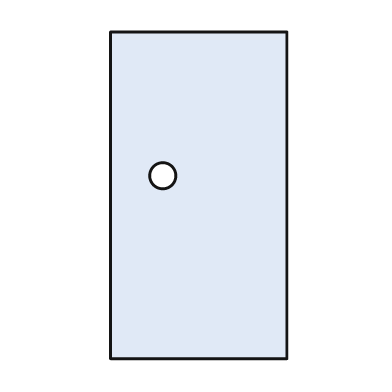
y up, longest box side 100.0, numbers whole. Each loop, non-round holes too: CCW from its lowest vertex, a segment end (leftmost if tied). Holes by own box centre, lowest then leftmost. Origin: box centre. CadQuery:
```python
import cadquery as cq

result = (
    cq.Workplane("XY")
    .moveTo(-27.0, -50.0)
    .lineTo(27.0, -50.0)
    .lineTo(27.0, 50.0)
    .lineTo(-27.0, 50.0)
    .close()
    .moveTo(-11.0, 6.0)
    .circle(4.0)
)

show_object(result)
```